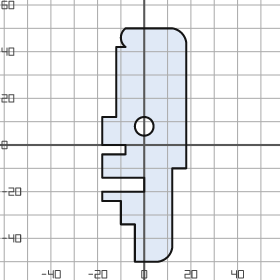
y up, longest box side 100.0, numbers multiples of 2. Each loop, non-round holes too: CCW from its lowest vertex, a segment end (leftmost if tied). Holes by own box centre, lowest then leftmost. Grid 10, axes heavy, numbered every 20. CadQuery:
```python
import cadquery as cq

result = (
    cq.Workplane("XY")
    .moveTo(-4.0, -50.0)
    .lineTo(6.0, -50.0)
    .threePointArc((10.0, -48.0), (12.0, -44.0))
    .lineTo(12.0, -10.0)
    .lineTo(18.0, -10.0)
    .lineTo(18.0, 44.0)
    .threePointArc((16.0, 48.0), (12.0, 50.0))
    .lineTo(-8.0, 50.0)
    .threePointArc((-10.0, 46.0), (-8.0, 42.0))
    .lineTo(-12.0, 42.0)
    .lineTo(-12.0, 12.0)
    .lineTo(-18.0, 12.0)
    .lineTo(-18.0, 0.0)
    .lineTo(-8.0, 0.0)
    .lineTo(-8.0, -4.0)
    .lineTo(-18.0, -4.0)
    .lineTo(-18.0, -14.0)
    .lineTo(0.0, -14.0)
    .lineTo(0.0, -20.0)
    .lineTo(-18.0, -20.0)
    .lineTo(-18.0, -24.0)
    .lineTo(-10.0, -24.0)
    .lineTo(-10.0, -34.0)
    .lineTo(-4.0, -34.0)
    .close()
    .moveTo(0.0, 8.0)
    .circle(4.0)
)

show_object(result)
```